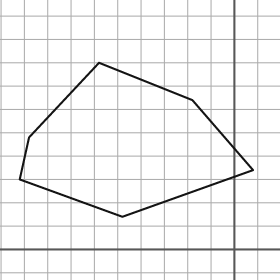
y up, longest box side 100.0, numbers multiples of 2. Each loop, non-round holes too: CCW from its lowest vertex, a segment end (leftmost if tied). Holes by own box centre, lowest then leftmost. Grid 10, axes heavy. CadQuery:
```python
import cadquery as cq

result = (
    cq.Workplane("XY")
    .moveTo(-48.0, 14.0)
    .lineTo(8.0, 34.0)
    .lineTo(-18.0, 64.0)
    .lineTo(-58.0, 80.0)
    .lineTo(-88.0, 48.0)
    .lineTo(-92.0, 30.0)
    .close()
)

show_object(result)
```